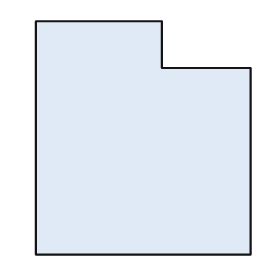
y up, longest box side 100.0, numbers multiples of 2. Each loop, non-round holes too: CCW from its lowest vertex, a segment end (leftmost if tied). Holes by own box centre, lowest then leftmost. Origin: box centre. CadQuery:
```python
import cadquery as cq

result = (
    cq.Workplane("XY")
    .moveTo(-46.0, -50.0)
    .lineTo(46.0, -50.0)
    .lineTo(46.0, 30.0)
    .lineTo(8.0, 30.0)
    .lineTo(8.0, 50.0)
    .lineTo(-46.0, 50.0)
    .close()
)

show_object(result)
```